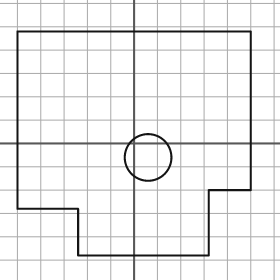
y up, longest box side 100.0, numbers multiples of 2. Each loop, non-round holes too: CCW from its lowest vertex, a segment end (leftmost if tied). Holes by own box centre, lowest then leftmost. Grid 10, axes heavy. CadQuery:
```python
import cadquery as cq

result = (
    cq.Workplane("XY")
    .moveTo(-24.0, -48.0)
    .lineTo(32.0, -48.0)
    .lineTo(32.0, -20.0)
    .lineTo(50.0, -20.0)
    .lineTo(50.0, 48.0)
    .lineTo(-50.0, 48.0)
    .lineTo(-50.0, -28.0)
    .lineTo(-24.0, -28.0)
    .close()
    .moveTo(6.0, -6.0)
    .circle(10.0)
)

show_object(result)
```